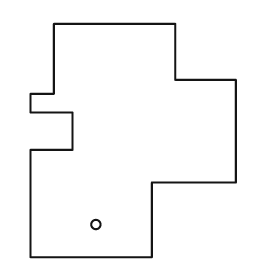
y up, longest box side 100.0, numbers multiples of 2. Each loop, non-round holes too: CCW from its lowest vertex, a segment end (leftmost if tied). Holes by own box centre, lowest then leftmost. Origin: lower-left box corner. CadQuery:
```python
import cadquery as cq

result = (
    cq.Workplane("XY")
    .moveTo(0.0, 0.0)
    .lineTo(52.0, 0.0)
    .lineTo(52.0, 32.0)
    .lineTo(88.0, 32.0)
    .lineTo(88.0, 76.0)
    .lineTo(62.0, 76.0)
    .lineTo(62.0, 100.0)
    .lineTo(10.0, 100.0)
    .lineTo(10.0, 70.0)
    .lineTo(0.0, 70.0)
    .lineTo(0.0, 62.0)
    .lineTo(18.0, 62.0)
    .lineTo(18.0, 46.0)
    .lineTo(0.0, 46.0)
    .close()
    .moveTo(28.0, 14.0)
    .circle(2.0)
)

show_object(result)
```